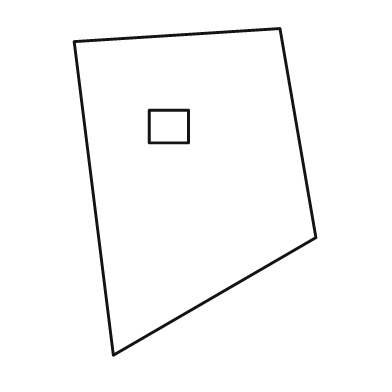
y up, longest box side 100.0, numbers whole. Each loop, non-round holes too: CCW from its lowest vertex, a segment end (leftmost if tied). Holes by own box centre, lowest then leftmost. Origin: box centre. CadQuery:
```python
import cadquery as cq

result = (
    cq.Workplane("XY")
    .moveTo(-25.0, -50.0)
    .lineTo(37.0, -14.0)
    .lineTo(26.0, 50.0)
    .lineTo(-37.0, 46.0)
    .close()
    .moveTo(-14.0, 15.0)
    .lineTo(-2.0, 15.0)
    .lineTo(-2.0, 25.0)
    .lineTo(-14.0, 25.0)
    .close()
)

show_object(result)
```